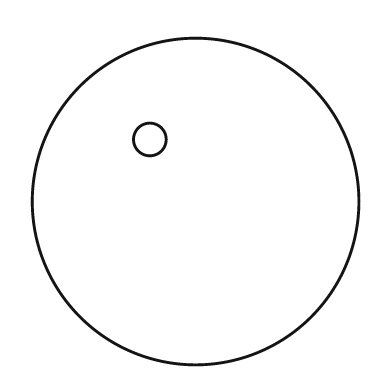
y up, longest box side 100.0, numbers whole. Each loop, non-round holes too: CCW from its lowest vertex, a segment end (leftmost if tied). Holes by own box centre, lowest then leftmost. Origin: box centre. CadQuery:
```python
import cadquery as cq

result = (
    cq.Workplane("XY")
    .moveTo(0.0, 0.0)
    .circle(50.0)
    .moveTo(-14.0, 19.0)
    .circle(5.0)
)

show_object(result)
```